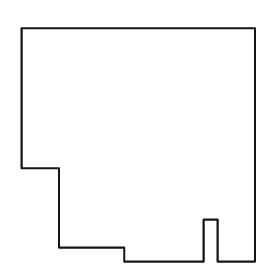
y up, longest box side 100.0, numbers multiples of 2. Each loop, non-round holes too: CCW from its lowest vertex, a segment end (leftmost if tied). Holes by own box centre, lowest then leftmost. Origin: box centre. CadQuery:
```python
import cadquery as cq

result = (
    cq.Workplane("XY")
    .moveTo(-6.0, -50.0)
    .lineTo(28.0, -50.0)
    .lineTo(28.0, -32.0)
    .lineTo(34.0, -32.0)
    .lineTo(34.0, -50.0)
    .lineTo(50.0, -50.0)
    .lineTo(50.0, 50.0)
    .lineTo(-50.0, 50.0)
    .lineTo(-50.0, -10.0)
    .lineTo(-34.0, -10.0)
    .lineTo(-34.0, -44.0)
    .lineTo(-6.0, -44.0)
    .close()
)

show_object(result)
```